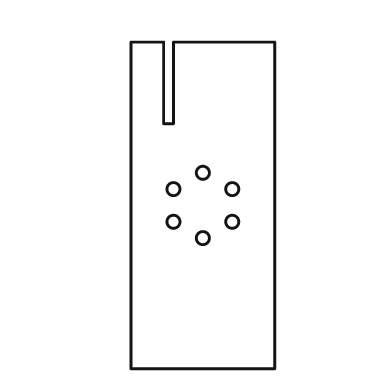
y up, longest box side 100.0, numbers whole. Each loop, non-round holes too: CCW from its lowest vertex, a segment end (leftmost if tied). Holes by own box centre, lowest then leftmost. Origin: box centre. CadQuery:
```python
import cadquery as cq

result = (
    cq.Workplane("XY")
    .moveTo(-22.0, -50.0)
    .lineTo(22.0, -50.0)
    .lineTo(22.0, 50.0)
    .lineTo(-9.0, 50.0)
    .lineTo(-9.0, 25.0)
    .lineTo(-12.0, 25.0)
    .lineTo(-12.0, 50.0)
    .lineTo(-22.0, 50.0)
    .close()
    .moveTo(0.0, -10.0)
    .circle(2.0)
    .moveTo(-9.0, -5.0)
    .circle(2.0)
    .moveTo(9.0, -5.0)
    .circle(2.0)
    .moveTo(-9.0, 5.0)
    .circle(2.0)
    .moveTo(9.0, 5.0)
    .circle(2.0)
    .moveTo(0.0, 10.0)
    .circle(2.0)
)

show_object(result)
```